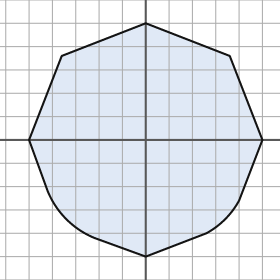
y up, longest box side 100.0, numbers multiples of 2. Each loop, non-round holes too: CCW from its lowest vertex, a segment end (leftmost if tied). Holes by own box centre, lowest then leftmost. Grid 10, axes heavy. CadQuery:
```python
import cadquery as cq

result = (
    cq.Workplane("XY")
    .moveTo(0.0, -50.0)
    .lineTo(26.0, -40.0)
    .threePointArc((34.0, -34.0), (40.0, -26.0))
    .lineTo(50.0, 0.0)
    .lineTo(36.0, 36.0)
    .lineTo(0.0, 50.0)
    .lineTo(-36.0, 36.0)
    .lineTo(-50.0, 0.0)
    .lineTo(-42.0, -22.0)
    .threePointArc((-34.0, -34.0), (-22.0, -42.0))
    .close()
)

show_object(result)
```